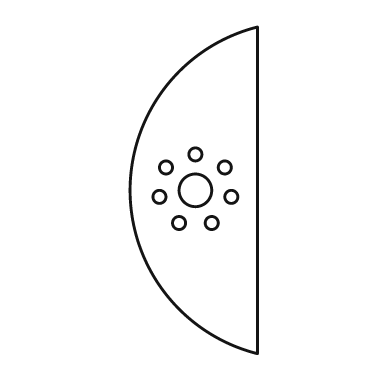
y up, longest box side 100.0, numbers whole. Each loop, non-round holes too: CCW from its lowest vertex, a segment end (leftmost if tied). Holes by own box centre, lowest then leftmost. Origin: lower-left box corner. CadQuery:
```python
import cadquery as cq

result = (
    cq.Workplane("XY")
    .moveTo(39.0, 0.0)
    .lineTo(39.0, 100.0)
    .threePointArc((0.0, 50.0), (39.0, 0.0))
    .close()
    .moveTo(15.0, 40.0)
    .circle(2.0)
    .moveTo(25.0, 40.0)
    .circle(2.0)
    .moveTo(9.0, 48.0)
    .circle(2.0)
    .moveTo(31.0, 48.0)
    .circle(2.0)
    .moveTo(20.0, 50.0)
    .circle(5.0)
    .moveTo(11.0, 57.0)
    .circle(2.0)
    .moveTo(29.0, 57.0)
    .circle(2.0)
    .moveTo(20.0, 61.0)
    .circle(2.0)
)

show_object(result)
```